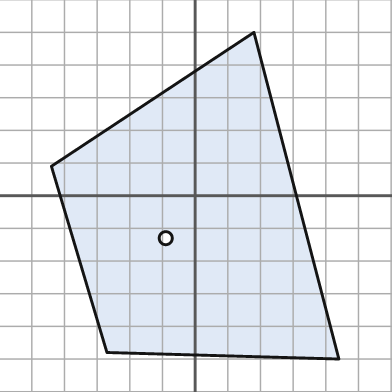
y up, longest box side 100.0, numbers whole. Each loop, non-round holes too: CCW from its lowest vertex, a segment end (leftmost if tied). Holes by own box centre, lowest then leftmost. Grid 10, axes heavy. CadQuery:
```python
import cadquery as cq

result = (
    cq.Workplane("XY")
    .moveTo(44.0, -50.0)
    .lineTo(18.0, 50.0)
    .lineTo(-44.0, 9.0)
    .lineTo(-27.0, -48.0)
    .close()
    .moveTo(-9.0, -13.0)
    .circle(2.0)
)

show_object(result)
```